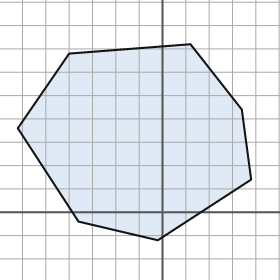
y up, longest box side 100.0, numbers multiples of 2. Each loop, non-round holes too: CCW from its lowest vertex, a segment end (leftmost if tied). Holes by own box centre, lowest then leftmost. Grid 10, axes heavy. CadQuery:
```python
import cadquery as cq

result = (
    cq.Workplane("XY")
    .moveTo(-2.0, -12.0)
    .lineTo(38.0, 14.0)
    .lineTo(34.0, 44.0)
    .lineTo(12.0, 72.0)
    .lineTo(-40.0, 68.0)
    .lineTo(-62.0, 36.0)
    .lineTo(-36.0, -4.0)
    .close()
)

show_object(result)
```